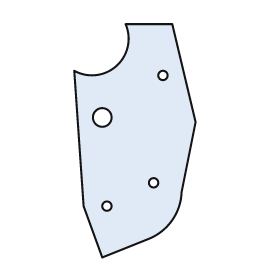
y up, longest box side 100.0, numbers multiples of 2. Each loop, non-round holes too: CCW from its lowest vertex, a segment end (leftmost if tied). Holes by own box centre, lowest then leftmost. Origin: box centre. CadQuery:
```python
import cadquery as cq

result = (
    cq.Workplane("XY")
    .moveTo(-14.0, -50.0)
    .lineTo(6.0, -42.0)
    .threePointArc((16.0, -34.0), (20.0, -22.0))
    .lineTo(26.0, 8.0)
    .lineTo(16.0, 50.0)
    .lineTo(-4.0, 50.0)
    .threePointArc((-8.0, 32.0), (-26.0, 30.0))
    .lineTo(-22.0, -28.0)
    .close()
    .moveTo(-12.0, -28.0)
    .circle(2.0)
    .moveTo(8.0, -18.0)
    .circle(2.0)
    .moveTo(-14.0, 10.0)
    .circle(4.0)
    .moveTo(12.0, 28.0)
    .circle(2.0)
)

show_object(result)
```